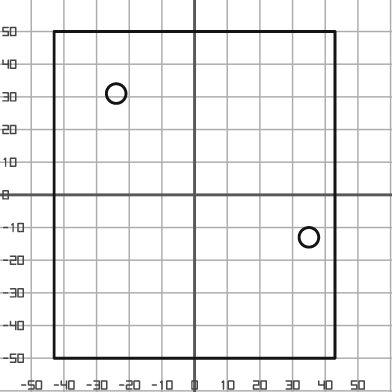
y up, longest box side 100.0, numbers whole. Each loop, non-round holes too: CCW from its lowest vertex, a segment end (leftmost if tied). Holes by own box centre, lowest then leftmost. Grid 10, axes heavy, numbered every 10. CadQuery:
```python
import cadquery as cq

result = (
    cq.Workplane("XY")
    .moveTo(-43.0, -50.0)
    .lineTo(43.0, -50.0)
    .lineTo(43.0, 50.0)
    .lineTo(-43.0, 50.0)
    .close()
    .moveTo(35.0, -13.0)
    .circle(3.0)
    .moveTo(-24.0, 31.0)
    .circle(3.0)
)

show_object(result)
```